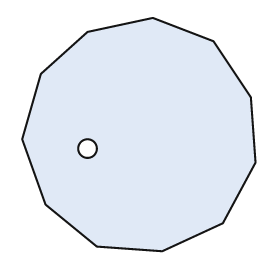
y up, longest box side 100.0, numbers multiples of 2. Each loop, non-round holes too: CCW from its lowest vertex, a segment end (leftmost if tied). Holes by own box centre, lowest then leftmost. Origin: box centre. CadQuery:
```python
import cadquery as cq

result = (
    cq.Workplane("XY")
    .moveTo(10.0, -50.0)
    .lineTo(36.0, -38.0)
    .lineTo(50.0, -12.0)
    .lineTo(48.0, 16.0)
    .lineTo(32.0, 40.0)
    .lineTo(6.0, 50.0)
    .lineTo(-22.0, 44.0)
    .lineTo(-42.0, 26.0)
    .lineTo(-50.0, -2.0)
    .lineTo(-40.0, -30.0)
    .lineTo(-18.0, -48.0)
    .close()
    .moveTo(-22.0, -6.0)
    .circle(4.0)
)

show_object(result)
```